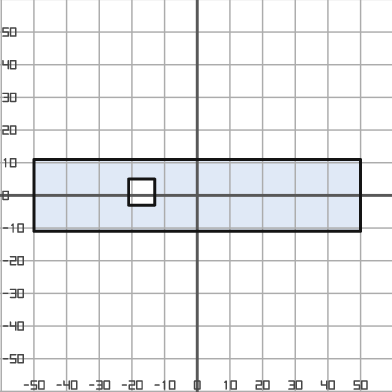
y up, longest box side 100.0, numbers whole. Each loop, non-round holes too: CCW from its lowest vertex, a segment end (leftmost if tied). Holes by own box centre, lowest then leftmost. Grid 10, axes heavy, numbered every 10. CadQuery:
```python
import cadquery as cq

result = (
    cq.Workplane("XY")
    .moveTo(-50.0, -11.0)
    .lineTo(50.0, -11.0)
    .lineTo(50.0, 11.0)
    .lineTo(-50.0, 11.0)
    .close()
    .moveTo(-21.0, -3.0)
    .lineTo(-13.0, -3.0)
    .lineTo(-13.0, 5.0)
    .lineTo(-21.0, 5.0)
    .close()
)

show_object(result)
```